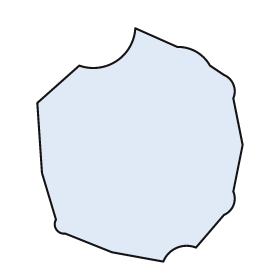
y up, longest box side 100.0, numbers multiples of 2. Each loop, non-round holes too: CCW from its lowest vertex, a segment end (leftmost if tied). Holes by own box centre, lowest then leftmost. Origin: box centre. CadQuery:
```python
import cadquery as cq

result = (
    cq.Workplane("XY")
    .moveTo(10.0, -50.0)
    .threePointArc((16.0, -44.0), (24.0, -44.0))
    .lineTo(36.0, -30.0)
    .threePointArc((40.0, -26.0), (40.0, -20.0))
    .lineTo(44.0, 0.0)
    .lineTo(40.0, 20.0)
    .threePointArc((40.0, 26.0), (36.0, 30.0))
    .lineTo(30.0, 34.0)
    .threePointArc((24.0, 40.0), (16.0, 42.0))
    .lineTo(-2.0, 50.0)
    .threePointArc((-10.0, 36.0), (-26.0, 34.0))
    .lineTo(-44.0, 18.0)
    .lineTo(-42.0, -12.0)
    .lineTo(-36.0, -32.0)
    .threePointArc((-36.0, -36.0), (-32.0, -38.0))
    .lineTo(-12.0, -46.0)
    .close()
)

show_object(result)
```